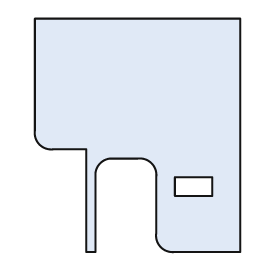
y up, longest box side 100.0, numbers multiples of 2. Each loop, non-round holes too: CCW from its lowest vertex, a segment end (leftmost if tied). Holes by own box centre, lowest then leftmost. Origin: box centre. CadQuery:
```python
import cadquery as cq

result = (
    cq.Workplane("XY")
    .moveTo(-22.0, -50.0)
    .lineTo(-18.0, -50.0)
    .lineTo(-18.0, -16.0)
    .threePointArc((-16.0, -12.0), (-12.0, -10.0))
    .lineTo(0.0, -10.0)
    .threePointArc((6.0, -12.0), (8.0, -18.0))
    .lineTo(8.0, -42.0)
    .threePointArc((10.0, -48.0), (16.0, -50.0))
    .lineTo(44.0, -50.0)
    .lineTo(44.0, 50.0)
    .lineTo(-44.0, 50.0)
    .lineTo(-44.0, 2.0)
    .threePointArc((-42.0, -4.0), (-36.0, -6.0))
    .lineTo(-22.0, -6.0)
    .close()
    .moveTo(16.0, -26.0)
    .lineTo(32.0, -26.0)
    .lineTo(32.0, -18.0)
    .lineTo(16.0, -18.0)
    .close()
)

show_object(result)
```